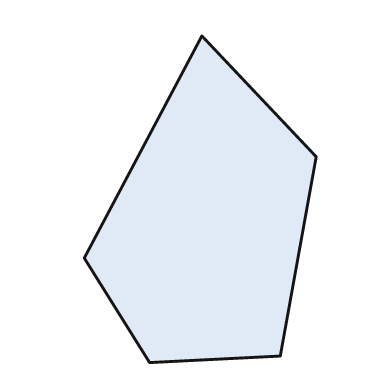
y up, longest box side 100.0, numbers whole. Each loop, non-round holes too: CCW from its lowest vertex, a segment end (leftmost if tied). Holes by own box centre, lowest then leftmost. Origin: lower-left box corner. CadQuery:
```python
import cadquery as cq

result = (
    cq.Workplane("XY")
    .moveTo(20.0, 0.0)
    .lineTo(60.0, 2.0)
    .lineTo(71.0, 63.0)
    .lineTo(36.0, 100.0)
    .lineTo(0.0, 32.0)
    .close()
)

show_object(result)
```